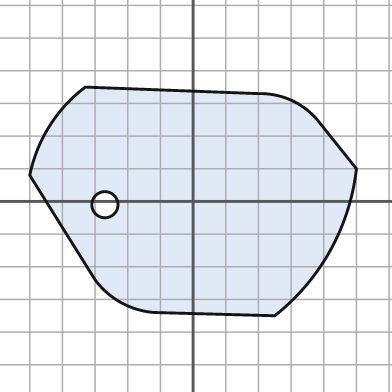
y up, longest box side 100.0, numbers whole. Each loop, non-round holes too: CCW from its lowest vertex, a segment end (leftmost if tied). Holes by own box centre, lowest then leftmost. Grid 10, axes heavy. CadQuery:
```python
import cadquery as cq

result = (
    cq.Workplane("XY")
    .moveTo(25.0, -35.0)
    .threePointArc((42.0, -15.0), (50.0, 10.0))
    .lineTo(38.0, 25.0)
    .threePointArc((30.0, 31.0), (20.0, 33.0))
    .lineTo(-33.0, 35.0)
    .threePointArc((-44.0, 23.0), (-50.0, 8.0))
    .lineTo(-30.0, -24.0)
    .threePointArc((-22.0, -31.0), (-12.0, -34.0))
    .close()
    .moveTo(-27.0, -1.0)
    .circle(4.0)
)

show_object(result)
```